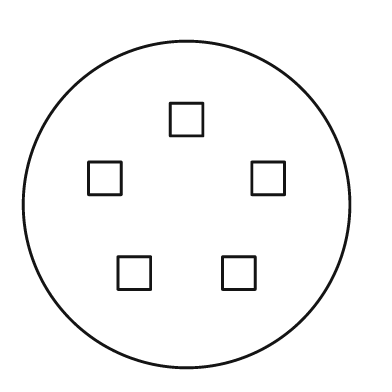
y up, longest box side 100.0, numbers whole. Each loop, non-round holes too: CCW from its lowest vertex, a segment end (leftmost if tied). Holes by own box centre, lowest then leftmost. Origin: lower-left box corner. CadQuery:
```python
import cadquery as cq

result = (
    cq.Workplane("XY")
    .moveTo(50.0, 50.0)
    .circle(50.0)
    .moveTo(29.0, 24.0)
    .lineTo(39.0, 24.0)
    .lineTo(39.0, 34.0)
    .lineTo(29.0, 34.0)
    .close()
    .moveTo(61.0, 24.0)
    .lineTo(71.0, 24.0)
    .lineTo(71.0, 34.0)
    .lineTo(61.0, 34.0)
    .close()
    .moveTo(20.0, 53.0)
    .lineTo(30.0, 53.0)
    .lineTo(30.0, 63.0)
    .lineTo(20.0, 63.0)
    .close()
    .moveTo(70.0, 53.0)
    .lineTo(80.0, 53.0)
    .lineTo(80.0, 63.0)
    .lineTo(70.0, 63.0)
    .close()
    .moveTo(45.0, 71.0)
    .lineTo(55.0, 71.0)
    .lineTo(55.0, 81.0)
    .lineTo(45.0, 81.0)
    .close()
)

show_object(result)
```